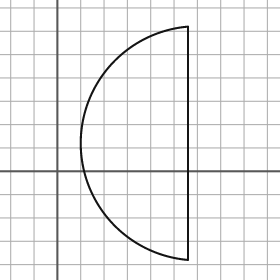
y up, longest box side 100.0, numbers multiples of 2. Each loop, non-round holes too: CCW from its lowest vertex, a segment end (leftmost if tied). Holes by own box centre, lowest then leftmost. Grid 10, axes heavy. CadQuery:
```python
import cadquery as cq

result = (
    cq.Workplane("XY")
    .moveTo(56.0, -38.0)
    .lineTo(56.0, 62.0)
    .threePointArc((10.0, 12.0), (56.0, -38.0))
    .close()
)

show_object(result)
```